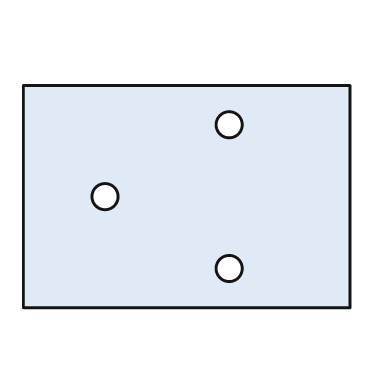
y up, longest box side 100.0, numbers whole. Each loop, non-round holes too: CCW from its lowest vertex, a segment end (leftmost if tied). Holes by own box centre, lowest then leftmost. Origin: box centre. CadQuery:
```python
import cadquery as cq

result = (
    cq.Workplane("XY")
    .moveTo(-50.0, -34.0)
    .lineTo(50.0, -34.0)
    .lineTo(50.0, 34.0)
    .lineTo(-50.0, 34.0)
    .close()
    .moveTo(13.0, -22.0)
    .circle(4.0)
    .moveTo(-25.0, 0.0)
    .circle(4.0)
    .moveTo(13.0, 22.0)
    .circle(4.0)
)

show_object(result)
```